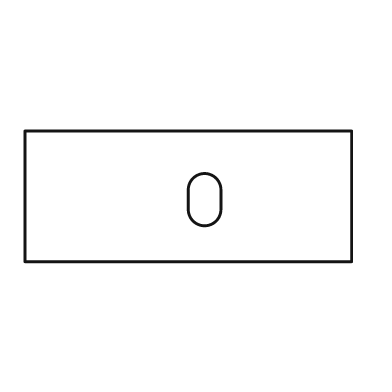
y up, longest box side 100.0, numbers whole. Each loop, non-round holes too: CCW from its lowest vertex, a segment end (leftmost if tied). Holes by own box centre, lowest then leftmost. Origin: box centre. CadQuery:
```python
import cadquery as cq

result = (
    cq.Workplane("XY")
    .moveTo(-50.0, -20.0)
    .lineTo(50.0, -20.0)
    .lineTo(50.0, 20.0)
    .lineTo(-50.0, 20.0)
    .close()
    .moveTo(0.0, -4.0)
    .threePointArc((5.0, -9.0), (10.0, -4.0))
    .lineTo(10.0, 2.0)
    .threePointArc((5.0, 7.0), (0.0, 2.0))
    .close()
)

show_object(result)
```